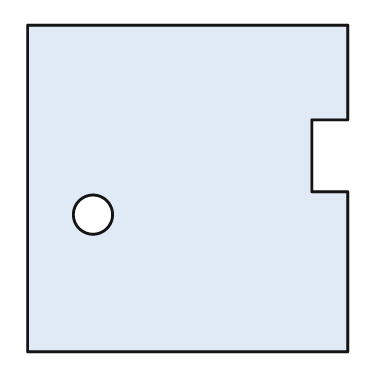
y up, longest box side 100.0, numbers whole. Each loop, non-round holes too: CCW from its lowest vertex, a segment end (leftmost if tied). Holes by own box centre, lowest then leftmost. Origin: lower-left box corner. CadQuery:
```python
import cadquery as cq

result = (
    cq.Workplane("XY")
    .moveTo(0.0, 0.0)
    .lineTo(98.0, 0.0)
    .lineTo(98.0, 49.0)
    .lineTo(87.0, 49.0)
    .lineTo(87.0, 71.0)
    .lineTo(98.0, 71.0)
    .lineTo(98.0, 100.0)
    .lineTo(0.0, 100.0)
    .close()
    .moveTo(20.0, 42.0)
    .circle(6.0)
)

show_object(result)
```